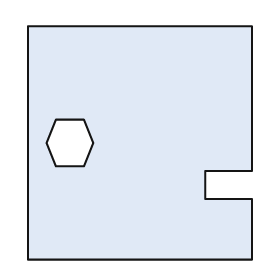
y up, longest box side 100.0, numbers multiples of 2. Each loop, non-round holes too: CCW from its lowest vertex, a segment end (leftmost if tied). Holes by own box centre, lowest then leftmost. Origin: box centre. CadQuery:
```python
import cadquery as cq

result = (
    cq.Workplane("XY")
    .moveTo(-48.0, -50.0)
    .lineTo(48.0, -50.0)
    .lineTo(48.0, -24.0)
    .lineTo(28.0, -24.0)
    .lineTo(28.0, -12.0)
    .lineTo(48.0, -12.0)
    .lineTo(48.0, 50.0)
    .lineTo(-48.0, 50.0)
    .close()
    .moveTo(-36.0, -10.0)
    .lineTo(-24.0, -10.0)
    .lineTo(-20.0, 0.0)
    .lineTo(-24.0, 10.0)
    .lineTo(-36.0, 10.0)
    .lineTo(-40.0, 0.0)
    .close()
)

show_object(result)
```